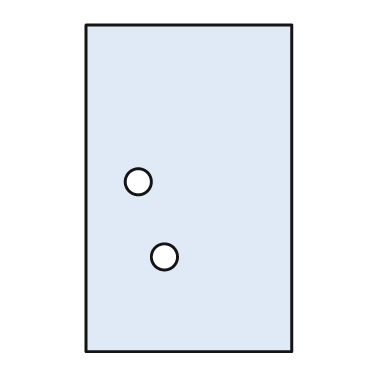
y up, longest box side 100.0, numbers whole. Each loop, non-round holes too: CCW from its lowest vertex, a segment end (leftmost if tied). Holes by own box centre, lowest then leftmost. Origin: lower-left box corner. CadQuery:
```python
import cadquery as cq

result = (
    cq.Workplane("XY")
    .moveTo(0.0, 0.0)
    .lineTo(63.0, 0.0)
    .lineTo(63.0, 100.0)
    .lineTo(0.0, 100.0)
    .close()
    .moveTo(24.0, 29.0)
    .circle(4.0)
    .moveTo(16.0, 52.0)
    .circle(4.0)
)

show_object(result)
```